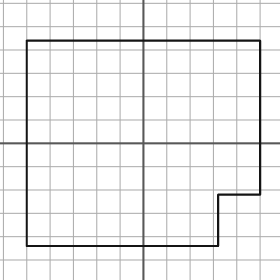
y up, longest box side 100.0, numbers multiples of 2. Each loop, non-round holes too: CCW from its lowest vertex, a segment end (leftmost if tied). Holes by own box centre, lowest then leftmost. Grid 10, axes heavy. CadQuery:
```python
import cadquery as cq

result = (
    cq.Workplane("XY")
    .moveTo(-50.0, -44.0)
    .lineTo(32.0, -44.0)
    .lineTo(32.0, -22.0)
    .lineTo(50.0, -22.0)
    .lineTo(50.0, 44.0)
    .lineTo(-50.0, 44.0)
    .close()
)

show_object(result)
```